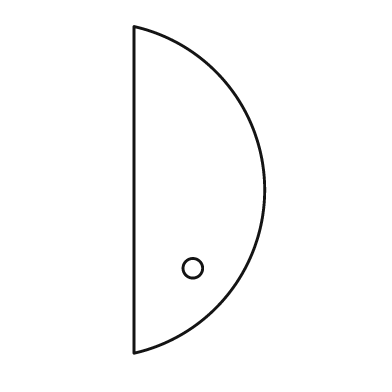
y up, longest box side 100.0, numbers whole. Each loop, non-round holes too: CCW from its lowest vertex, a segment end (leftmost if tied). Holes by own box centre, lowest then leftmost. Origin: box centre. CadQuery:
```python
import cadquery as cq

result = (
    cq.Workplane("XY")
    .moveTo(-20.0, -50.0)
    .threePointArc((20.0, 0.0), (-20.0, 50.0))
    .close()
    .moveTo(-2.0, -24.0)
    .circle(3.0)
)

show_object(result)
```